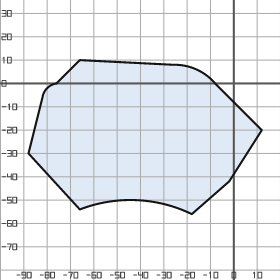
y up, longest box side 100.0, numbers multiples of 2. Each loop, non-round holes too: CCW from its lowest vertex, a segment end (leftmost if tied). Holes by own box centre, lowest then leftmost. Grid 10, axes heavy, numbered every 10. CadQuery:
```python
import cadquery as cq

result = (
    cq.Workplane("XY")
    .moveTo(-18.0, -56.0)
    .lineTo(-2.0, -42.0)
    .lineTo(12.0, -20.0)
    .lineTo(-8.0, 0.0)
    .threePointArc((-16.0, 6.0), (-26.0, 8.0))
    .lineTo(-66.0, 10.0)
    .lineTo(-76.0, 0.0)
    .threePointArc((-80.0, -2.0), (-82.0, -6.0))
    .lineTo(-88.0, -30.0)
    .lineTo(-66.0, -54.0)
    .threePointArc((-42.0, -50.0), (-18.0, -56.0))
    .close()
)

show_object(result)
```